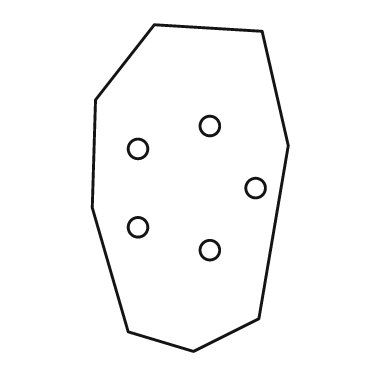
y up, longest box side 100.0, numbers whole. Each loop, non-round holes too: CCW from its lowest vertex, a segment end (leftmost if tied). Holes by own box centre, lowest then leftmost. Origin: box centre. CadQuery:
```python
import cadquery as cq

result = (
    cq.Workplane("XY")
    .moveTo(1.0, -50.0)
    .lineTo(21.0, -40.0)
    .lineTo(30.0, 13.0)
    .lineTo(22.0, 48.0)
    .lineTo(-11.0, 50.0)
    .lineTo(-29.0, 27.0)
    .lineTo(-30.0, -6.0)
    .lineTo(-19.0, -44.0)
    .close()
    .moveTo(6.0, -19.0)
    .circle(3.0)
    .moveTo(-16.0, -12.0)
    .circle(3.0)
    .moveTo(20.0, 0.0)
    .circle(3.0)
    .moveTo(-16.0, 12.0)
    .circle(3.0)
    .moveTo(6.0, 19.0)
    .circle(3.0)
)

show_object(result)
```